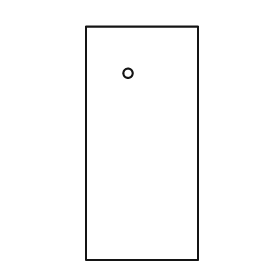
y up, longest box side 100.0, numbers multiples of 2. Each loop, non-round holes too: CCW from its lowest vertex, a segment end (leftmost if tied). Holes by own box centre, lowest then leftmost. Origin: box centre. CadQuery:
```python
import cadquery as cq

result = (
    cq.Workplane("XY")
    .moveTo(-24.0, -50.0)
    .lineTo(24.0, -50.0)
    .lineTo(24.0, 50.0)
    .lineTo(-24.0, 50.0)
    .close()
    .moveTo(-6.0, 30.0)
    .circle(2.0)
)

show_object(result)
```